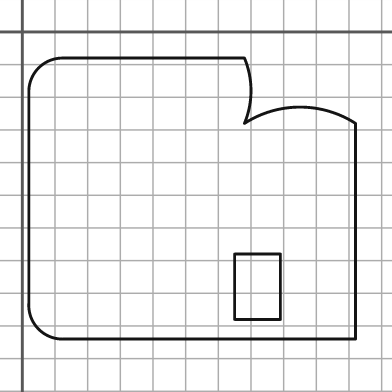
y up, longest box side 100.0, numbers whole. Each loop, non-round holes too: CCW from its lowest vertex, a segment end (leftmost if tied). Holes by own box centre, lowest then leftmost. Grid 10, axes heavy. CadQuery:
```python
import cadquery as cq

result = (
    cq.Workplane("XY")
    .moveTo(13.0, -94.0)
    .lineTo(102.0, -94.0)
    .lineTo(102.0, -28.0)
    .threePointArc((85.0, -23.0), (68.0, -28.0))
    .threePointArc((70.0, -18.0), (68.0, -8.0))
    .lineTo(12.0, -8.0)
    .threePointArc((5.0, -11.0), (2.0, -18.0))
    .lineTo(2.0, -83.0)
    .threePointArc((5.0, -91.0), (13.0, -94.0))
    .close()
    .moveTo(65.0, -88.0)
    .lineTo(79.0, -88.0)
    .lineTo(79.0, -68.0)
    .lineTo(65.0, -68.0)
    .close()
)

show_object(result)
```